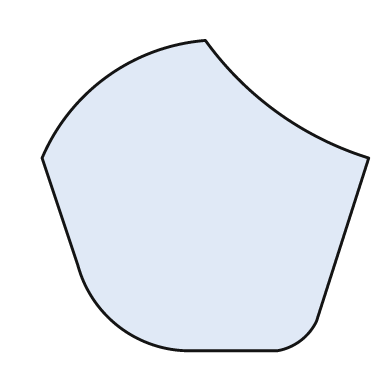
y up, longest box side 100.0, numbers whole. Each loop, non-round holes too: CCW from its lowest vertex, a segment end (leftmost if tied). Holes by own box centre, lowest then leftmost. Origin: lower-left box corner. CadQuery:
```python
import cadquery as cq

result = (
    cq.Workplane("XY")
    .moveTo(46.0, 0.0)
    .lineTo(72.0, 0.0)
    .threePointArc((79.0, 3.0), (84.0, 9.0))
    .lineTo(100.0, 59.0)
    .threePointArc((72.0, 73.0), (50.0, 95.0))
    .threePointArc((20.0, 84.0), (0.0, 59.0))
    .lineTo(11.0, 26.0)
    .threePointArc((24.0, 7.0), (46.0, 0.0))
    .close()
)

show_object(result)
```